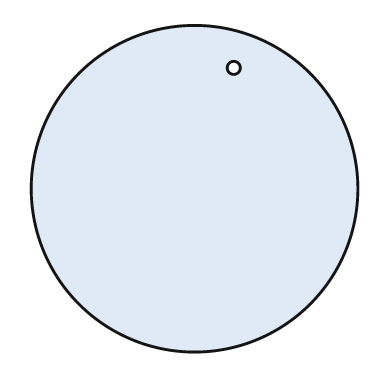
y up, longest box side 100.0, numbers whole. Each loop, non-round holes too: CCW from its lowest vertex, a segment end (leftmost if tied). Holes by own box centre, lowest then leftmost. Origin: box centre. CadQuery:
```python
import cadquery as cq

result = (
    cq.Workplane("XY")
    .moveTo(0.0, 0.0)
    .circle(50.0)
    .moveTo(12.0, 37.0)
    .circle(2.0)
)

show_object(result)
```